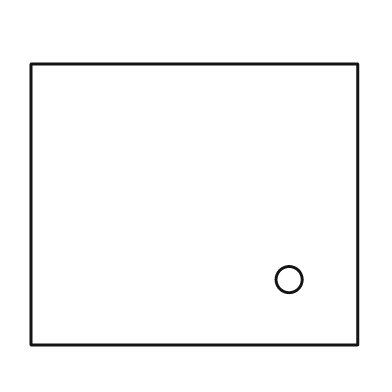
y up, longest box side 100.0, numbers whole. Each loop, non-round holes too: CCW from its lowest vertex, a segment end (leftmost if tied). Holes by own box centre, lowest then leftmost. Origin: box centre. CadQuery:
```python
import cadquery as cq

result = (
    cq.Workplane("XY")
    .moveTo(-50.0, -43.0)
    .lineTo(50.0, -43.0)
    .lineTo(50.0, 43.0)
    .lineTo(-50.0, 43.0)
    .close()
    .moveTo(29.0, -23.0)
    .circle(4.0)
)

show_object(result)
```